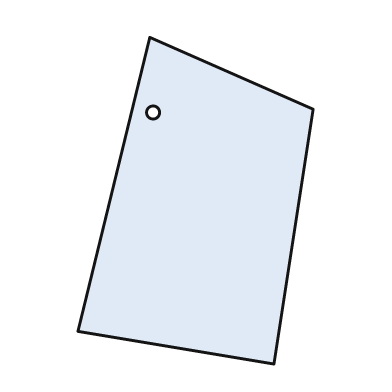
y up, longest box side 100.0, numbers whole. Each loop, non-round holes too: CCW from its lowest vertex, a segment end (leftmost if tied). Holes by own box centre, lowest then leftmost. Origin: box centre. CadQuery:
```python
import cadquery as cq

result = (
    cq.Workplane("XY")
    .moveTo(24.0, -50.0)
    .lineTo(36.0, 28.0)
    .lineTo(-14.0, 50.0)
    .lineTo(-36.0, -40.0)
    .close()
    .moveTo(-13.0, 27.0)
    .circle(2.0)
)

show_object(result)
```